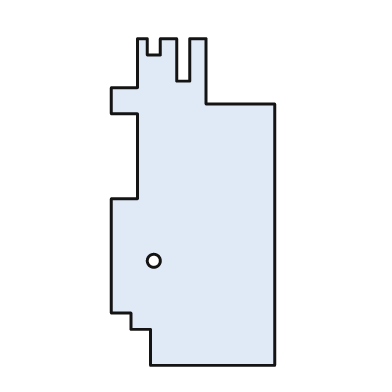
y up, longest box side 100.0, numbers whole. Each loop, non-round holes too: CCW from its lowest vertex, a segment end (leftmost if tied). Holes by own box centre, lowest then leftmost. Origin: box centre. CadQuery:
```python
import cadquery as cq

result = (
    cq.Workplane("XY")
    .moveTo(-13.0, -50.0)
    .lineTo(25.0, -50.0)
    .lineTo(25.0, 30.0)
    .lineTo(4.0, 30.0)
    .lineTo(4.0, 50.0)
    .lineTo(-1.0, 50.0)
    .lineTo(-1.0, 37.0)
    .lineTo(-5.0, 37.0)
    .lineTo(-5.0, 50.0)
    .lineTo(-10.0, 50.0)
    .lineTo(-10.0, 45.0)
    .lineTo(-14.0, 45.0)
    .lineTo(-14.0, 50.0)
    .lineTo(-17.0, 50.0)
    .lineTo(-17.0, 35.0)
    .lineTo(-25.0, 35.0)
    .lineTo(-25.0, 27.0)
    .lineTo(-17.0, 27.0)
    .lineTo(-17.0, 1.0)
    .lineTo(-25.0, 1.0)
    .lineTo(-25.0, -34.0)
    .lineTo(-19.0, -34.0)
    .lineTo(-19.0, -39.0)
    .lineTo(-13.0, -39.0)
    .close()
    .moveTo(-12.0, -18.0)
    .circle(2.0)
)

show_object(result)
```